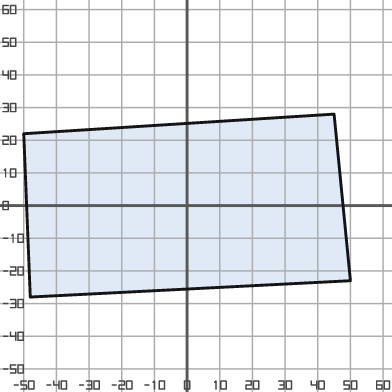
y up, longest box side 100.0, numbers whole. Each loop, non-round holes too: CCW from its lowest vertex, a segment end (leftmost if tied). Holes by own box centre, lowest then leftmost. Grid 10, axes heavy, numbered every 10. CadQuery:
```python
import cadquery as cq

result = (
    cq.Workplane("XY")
    .moveTo(-48.0, -28.0)
    .lineTo(50.0, -23.0)
    .lineTo(45.0, 28.0)
    .lineTo(-50.0, 22.0)
    .close()
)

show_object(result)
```